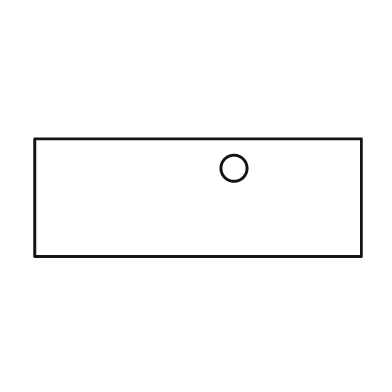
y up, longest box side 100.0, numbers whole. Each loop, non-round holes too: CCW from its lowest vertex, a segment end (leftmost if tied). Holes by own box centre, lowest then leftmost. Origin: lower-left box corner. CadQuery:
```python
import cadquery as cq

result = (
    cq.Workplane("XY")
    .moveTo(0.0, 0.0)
    .lineTo(100.0, 0.0)
    .lineTo(100.0, 36.0)
    .lineTo(0.0, 36.0)
    .close()
    .moveTo(61.0, 27.0)
    .circle(4.0)
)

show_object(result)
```